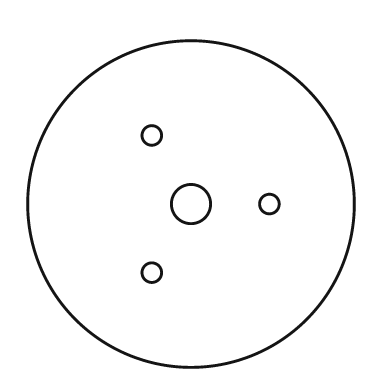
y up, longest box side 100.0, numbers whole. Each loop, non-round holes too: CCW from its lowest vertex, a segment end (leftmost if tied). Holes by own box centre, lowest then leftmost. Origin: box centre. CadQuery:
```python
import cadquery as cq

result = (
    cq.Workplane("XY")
    .moveTo(0.0, 0.0)
    .circle(50.0)
    .moveTo(-12.0, -21.0)
    .circle(3.0)
    .moveTo(0.0, 0.0)
    .circle(6.0)
    .moveTo(24.0, 0.0)
    .circle(3.0)
    .moveTo(-12.0, 21.0)
    .circle(3.0)
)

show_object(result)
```